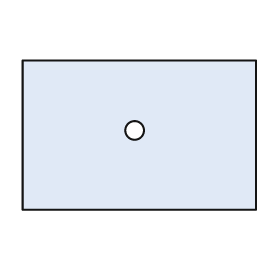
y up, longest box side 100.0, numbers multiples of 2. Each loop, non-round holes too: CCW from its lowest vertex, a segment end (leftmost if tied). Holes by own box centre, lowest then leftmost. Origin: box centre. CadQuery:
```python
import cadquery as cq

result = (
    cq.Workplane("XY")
    .moveTo(-50.0, -32.0)
    .lineTo(50.0, -32.0)
    .lineTo(50.0, 32.0)
    .lineTo(-50.0, 32.0)
    .close()
    .moveTo(-2.0, 2.0)
    .circle(4.0)
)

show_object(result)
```